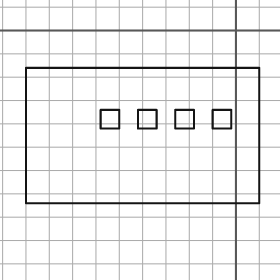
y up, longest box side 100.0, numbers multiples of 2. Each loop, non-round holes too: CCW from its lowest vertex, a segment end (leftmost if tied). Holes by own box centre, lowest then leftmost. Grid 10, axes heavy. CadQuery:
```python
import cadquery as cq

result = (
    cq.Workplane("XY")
    .moveTo(-90.0, -74.0)
    .lineTo(10.0, -74.0)
    .lineTo(10.0, -16.0)
    .lineTo(-90.0, -16.0)
    .close()
    .moveTo(-58.0, -42.0)
    .lineTo(-50.0, -42.0)
    .lineTo(-50.0, -34.0)
    .lineTo(-58.0, -34.0)
    .close()
    .moveTo(-42.0, -42.0)
    .lineTo(-34.0, -42.0)
    .lineTo(-34.0, -34.0)
    .lineTo(-42.0, -34.0)
    .close()
    .moveTo(-26.0, -42.0)
    .lineTo(-18.0, -42.0)
    .lineTo(-18.0, -34.0)
    .lineTo(-26.0, -34.0)
    .close()
    .moveTo(-10.0, -42.0)
    .lineTo(-2.0, -42.0)
    .lineTo(-2.0, -34.0)
    .lineTo(-10.0, -34.0)
    .close()
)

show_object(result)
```